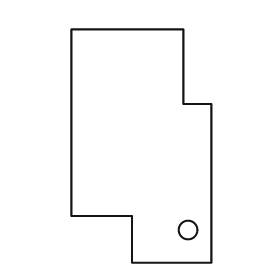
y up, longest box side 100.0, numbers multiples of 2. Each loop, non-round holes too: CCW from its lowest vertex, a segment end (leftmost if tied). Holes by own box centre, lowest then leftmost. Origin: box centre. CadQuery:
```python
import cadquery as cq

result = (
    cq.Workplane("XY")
    .moveTo(-4.0, -50.0)
    .lineTo(30.0, -50.0)
    .lineTo(30.0, 18.0)
    .lineTo(18.0, 18.0)
    .lineTo(18.0, 50.0)
    .lineTo(-30.0, 50.0)
    .lineTo(-30.0, -30.0)
    .lineTo(-4.0, -30.0)
    .close()
    .moveTo(20.0, -36.0)
    .circle(4.0)
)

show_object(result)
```